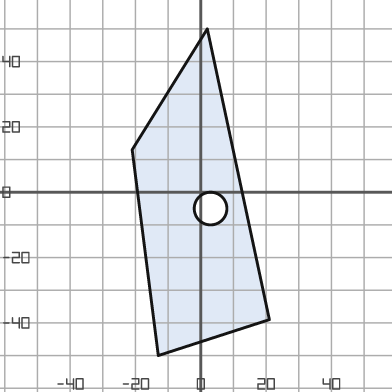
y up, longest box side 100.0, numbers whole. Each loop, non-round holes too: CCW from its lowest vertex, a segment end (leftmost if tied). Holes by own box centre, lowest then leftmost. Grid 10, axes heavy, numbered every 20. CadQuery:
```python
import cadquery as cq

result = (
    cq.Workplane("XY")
    .moveTo(-13.0, -50.0)
    .lineTo(21.0, -39.0)
    .lineTo(2.0, 50.0)
    .lineTo(-21.0, 13.0)
    .close()
    .moveTo(3.0, -5.0)
    .circle(5.0)
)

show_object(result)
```